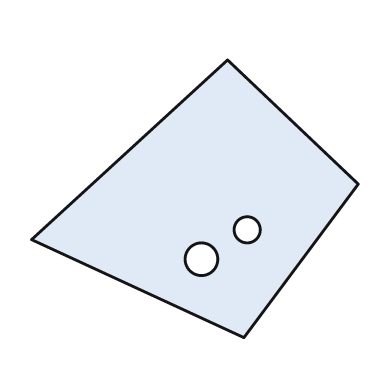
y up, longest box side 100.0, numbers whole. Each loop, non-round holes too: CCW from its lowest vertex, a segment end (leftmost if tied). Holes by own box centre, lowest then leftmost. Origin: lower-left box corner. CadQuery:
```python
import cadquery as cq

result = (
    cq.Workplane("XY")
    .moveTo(65.0, 0.0)
    .lineTo(100.0, 47.0)
    .lineTo(60.0, 85.0)
    .lineTo(0.0, 30.0)
    .close()
    .moveTo(52.0, 24.0)
    .circle(5.0)
    .moveTo(66.0, 33.0)
    .circle(4.0)
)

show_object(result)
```